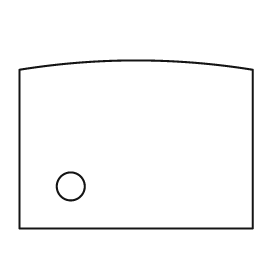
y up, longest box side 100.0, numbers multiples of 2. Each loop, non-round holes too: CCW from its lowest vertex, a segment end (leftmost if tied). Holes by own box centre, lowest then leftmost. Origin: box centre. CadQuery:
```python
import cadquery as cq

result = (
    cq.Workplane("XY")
    .moveTo(-50.0, -36.0)
    .lineTo(50.0, -36.0)
    .lineTo(50.0, 32.0)
    .threePointArc((0.0, 36.0), (-50.0, 32.0))
    .close()
    .moveTo(-28.0, -18.0)
    .circle(6.0)
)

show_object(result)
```